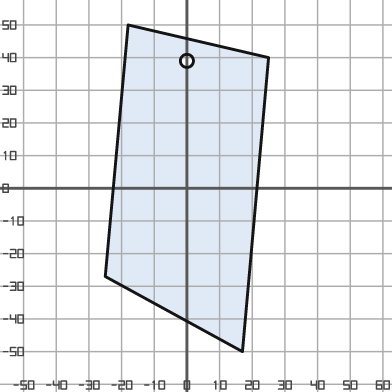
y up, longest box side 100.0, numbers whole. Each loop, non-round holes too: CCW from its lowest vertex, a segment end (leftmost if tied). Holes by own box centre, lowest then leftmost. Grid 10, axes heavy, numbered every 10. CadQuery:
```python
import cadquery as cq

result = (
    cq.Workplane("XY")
    .moveTo(17.0, -50.0)
    .lineTo(25.0, 40.0)
    .lineTo(-18.0, 50.0)
    .lineTo(-25.0, -27.0)
    .close()
    .moveTo(0.0, 39.0)
    .circle(2.0)
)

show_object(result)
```